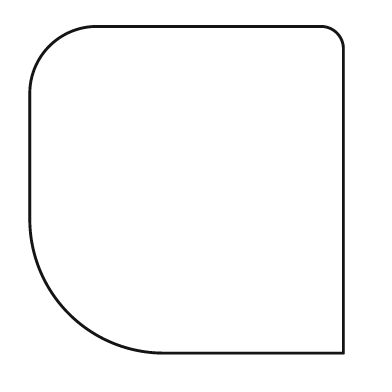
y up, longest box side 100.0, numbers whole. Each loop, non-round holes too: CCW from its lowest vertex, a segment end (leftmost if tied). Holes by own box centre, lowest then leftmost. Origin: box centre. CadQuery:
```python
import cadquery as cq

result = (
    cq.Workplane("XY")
    .moveTo(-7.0, -50.0)
    .lineTo(48.0, -50.0)
    .lineTo(48.0, 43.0)
    .threePointArc((46.0, 48.0), (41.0, 50.0))
    .lineTo(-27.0, 50.0)
    .threePointArc((-42.0, 44.0), (-48.0, 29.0))
    .lineTo(-48.0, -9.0)
    .threePointArc((-36.0, -38.0), (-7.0, -50.0))
    .close()
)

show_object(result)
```